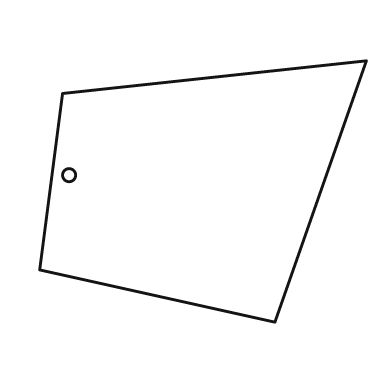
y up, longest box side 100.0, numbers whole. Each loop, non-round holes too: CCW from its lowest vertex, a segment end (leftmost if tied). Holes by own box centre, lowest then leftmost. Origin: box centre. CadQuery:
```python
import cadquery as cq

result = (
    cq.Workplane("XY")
    .moveTo(22.0, -40.0)
    .lineTo(50.0, 40.0)
    .lineTo(-43.0, 30.0)
    .lineTo(-50.0, -24.0)
    .close()
    .moveTo(-41.0, 5.0)
    .circle(2.0)
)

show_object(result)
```